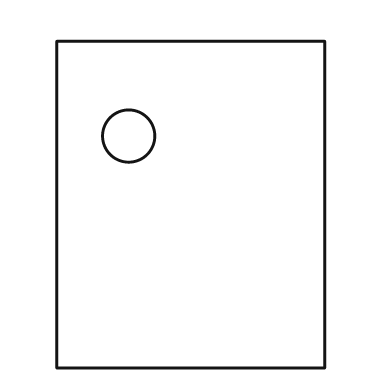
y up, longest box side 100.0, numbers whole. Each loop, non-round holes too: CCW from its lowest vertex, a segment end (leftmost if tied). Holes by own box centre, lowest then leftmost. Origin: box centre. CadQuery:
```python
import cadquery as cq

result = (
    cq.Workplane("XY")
    .moveTo(-41.0, -50.0)
    .lineTo(41.0, -50.0)
    .lineTo(41.0, 50.0)
    .lineTo(-41.0, 50.0)
    .close()
    .moveTo(-19.0, 21.0)
    .circle(8.0)
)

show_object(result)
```